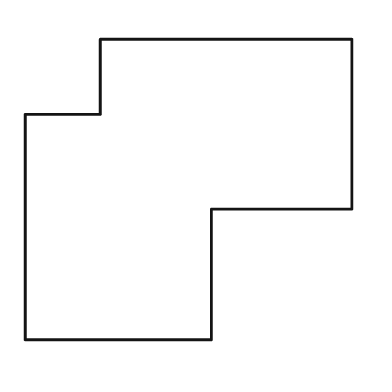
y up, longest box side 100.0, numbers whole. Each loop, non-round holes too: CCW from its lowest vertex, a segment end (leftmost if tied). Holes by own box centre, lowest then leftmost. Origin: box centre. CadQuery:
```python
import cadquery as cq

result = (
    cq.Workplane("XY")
    .moveTo(-50.0, -46.0)
    .lineTo(7.0, -46.0)
    .lineTo(7.0, -6.0)
    .lineTo(50.0, -6.0)
    .lineTo(50.0, 46.0)
    .lineTo(-27.0, 46.0)
    .lineTo(-27.0, 23.0)
    .lineTo(-50.0, 23.0)
    .close()
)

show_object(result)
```